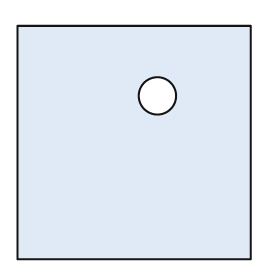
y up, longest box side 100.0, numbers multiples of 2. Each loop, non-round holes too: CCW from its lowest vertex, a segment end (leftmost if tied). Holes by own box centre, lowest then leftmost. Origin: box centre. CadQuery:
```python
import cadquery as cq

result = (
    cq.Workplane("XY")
    .moveTo(-50.0, -50.0)
    .lineTo(50.0, -50.0)
    .lineTo(50.0, 50.0)
    .lineTo(-50.0, 50.0)
    .close()
    .moveTo(10.0, 20.0)
    .circle(8.0)
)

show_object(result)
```